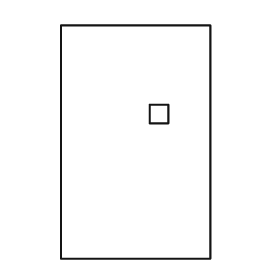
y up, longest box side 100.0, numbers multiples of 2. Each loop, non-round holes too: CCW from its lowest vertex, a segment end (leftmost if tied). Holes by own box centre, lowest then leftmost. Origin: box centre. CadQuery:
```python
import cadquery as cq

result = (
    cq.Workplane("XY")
    .moveTo(-32.0, -50.0)
    .lineTo(32.0, -50.0)
    .lineTo(32.0, 50.0)
    .lineTo(-32.0, 50.0)
    .close()
    .moveTo(6.0, 8.0)
    .lineTo(14.0, 8.0)
    .lineTo(14.0, 16.0)
    .lineTo(6.0, 16.0)
    .close()
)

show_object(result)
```